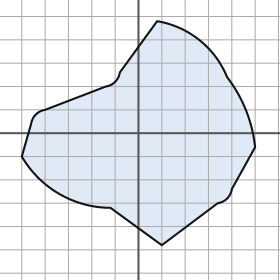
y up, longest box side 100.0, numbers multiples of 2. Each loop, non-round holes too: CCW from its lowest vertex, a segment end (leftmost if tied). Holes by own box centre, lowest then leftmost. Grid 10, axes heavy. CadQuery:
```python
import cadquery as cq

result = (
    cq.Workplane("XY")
    .moveTo(10.0, -48.0)
    .lineTo(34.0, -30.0)
    .threePointArc((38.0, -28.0), (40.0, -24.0))
    .lineTo(50.0, -6.0)
    .threePointArc((46.0, 10.0), (38.0, 24.0))
    .threePointArc((26.0, 40.0), (8.0, 48.0))
    .lineTo(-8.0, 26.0)
    .threePointArc((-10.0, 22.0), (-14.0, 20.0))
    .lineTo(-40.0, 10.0)
    .threePointArc((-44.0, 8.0), (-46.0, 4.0))
    .lineTo(-50.0, -10.0)
    .threePointArc((-34.0, -26.0), (-12.0, -32.0))
    .close()
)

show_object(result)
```